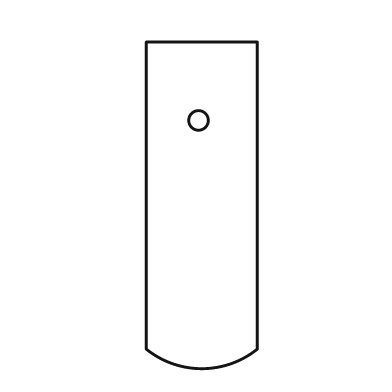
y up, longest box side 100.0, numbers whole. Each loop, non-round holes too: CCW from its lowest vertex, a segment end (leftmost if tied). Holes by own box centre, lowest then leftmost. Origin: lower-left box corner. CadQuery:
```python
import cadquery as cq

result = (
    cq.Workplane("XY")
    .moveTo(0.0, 6.0)
    .threePointArc((17.0, 0.0), (34.0, 6.0))
    .lineTo(34.0, 100.0)
    .lineTo(0.0, 100.0)
    .close()
    .moveTo(16.0, 76.0)
    .circle(3.0)
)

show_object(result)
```